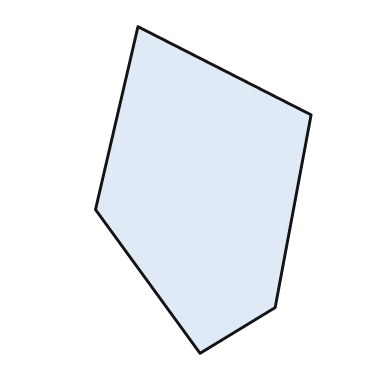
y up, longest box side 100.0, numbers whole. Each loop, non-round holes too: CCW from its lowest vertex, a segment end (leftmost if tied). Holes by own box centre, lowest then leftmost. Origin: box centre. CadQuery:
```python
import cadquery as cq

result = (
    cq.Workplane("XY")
    .moveTo(-1.0, -50.0)
    .lineTo(22.0, -36.0)
    .lineTo(33.0, 23.0)
    .lineTo(-20.0, 50.0)
    .lineTo(-33.0, -6.0)
    .close()
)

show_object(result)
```